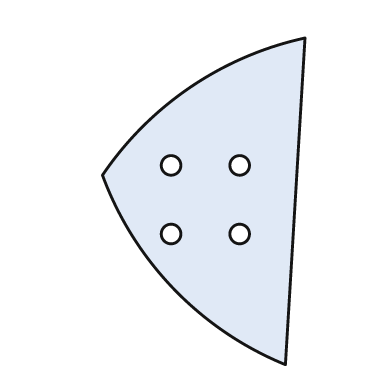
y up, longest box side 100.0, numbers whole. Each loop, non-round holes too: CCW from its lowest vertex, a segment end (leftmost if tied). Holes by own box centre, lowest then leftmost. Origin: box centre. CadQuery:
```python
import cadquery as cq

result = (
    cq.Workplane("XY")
    .moveTo(25.0, -50.0)
    .lineTo(31.0, 50.0)
    .threePointArc((-4.0, 35.0), (-31.0, 8.0))
    .threePointArc((-9.0, -27.0), (25.0, -50.0))
    .close()
    .moveTo(-10.0, -10.0)
    .circle(3.0)
    .moveTo(11.0, -10.0)
    .circle(3.0)
    .moveTo(-10.0, 11.0)
    .circle(3.0)
    .moveTo(11.0, 11.0)
    .circle(3.0)
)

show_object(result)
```